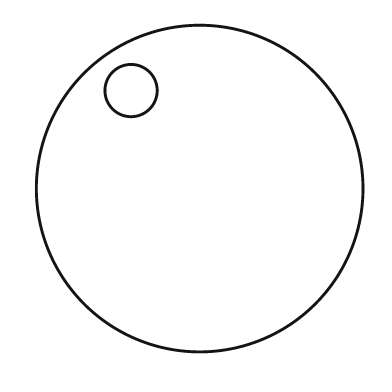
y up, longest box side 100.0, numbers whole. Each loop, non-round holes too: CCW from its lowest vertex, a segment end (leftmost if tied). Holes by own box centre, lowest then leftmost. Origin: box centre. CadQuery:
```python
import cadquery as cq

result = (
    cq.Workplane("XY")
    .moveTo(0.0, 0.0)
    .circle(50.0)
    .moveTo(-21.0, 30.0)
    .circle(8.0)
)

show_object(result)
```